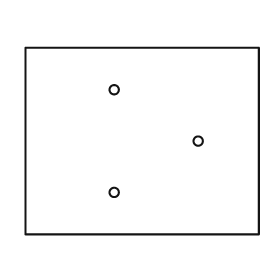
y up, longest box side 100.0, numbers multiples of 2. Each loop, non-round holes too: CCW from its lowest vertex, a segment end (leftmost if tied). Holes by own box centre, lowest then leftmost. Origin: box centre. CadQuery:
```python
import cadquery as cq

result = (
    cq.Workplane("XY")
    .moveTo(-50.0, -40.0)
    .lineTo(50.0, -40.0)
    .lineTo(50.0, 40.0)
    .lineTo(-50.0, 40.0)
    .close()
    .moveTo(-12.0, -22.0)
    .circle(2.0)
    .moveTo(24.0, 0.0)
    .circle(2.0)
    .moveTo(-12.0, 22.0)
    .circle(2.0)
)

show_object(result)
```